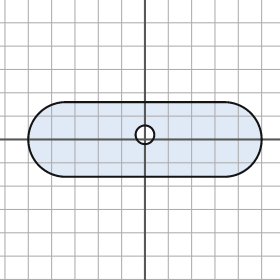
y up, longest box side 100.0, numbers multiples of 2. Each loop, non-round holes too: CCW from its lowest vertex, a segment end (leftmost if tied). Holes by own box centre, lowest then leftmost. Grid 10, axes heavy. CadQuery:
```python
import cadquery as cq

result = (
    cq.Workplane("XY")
    .moveTo(-34.0, -16.0)
    .lineTo(34.0, -16.0)
    .threePointArc((50.0, 0.0), (34.0, 16.0))
    .lineTo(-34.0, 16.0)
    .threePointArc((-50.0, 0.0), (-34.0, -16.0))
    .close()
    .moveTo(0.0, 2.0)
    .circle(4.0)
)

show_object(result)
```